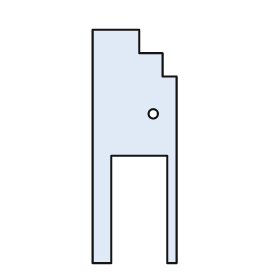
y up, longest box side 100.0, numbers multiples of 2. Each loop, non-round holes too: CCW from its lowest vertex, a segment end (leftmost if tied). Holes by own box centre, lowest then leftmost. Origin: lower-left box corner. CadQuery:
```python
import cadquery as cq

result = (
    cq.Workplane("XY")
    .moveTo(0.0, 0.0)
    .lineTo(8.0, 0.0)
    .lineTo(8.0, 46.0)
    .lineTo(32.0, 46.0)
    .lineTo(32.0, 0.0)
    .lineTo(36.0, 0.0)
    .lineTo(36.0, 80.0)
    .lineTo(30.0, 80.0)
    .lineTo(30.0, 90.0)
    .lineTo(20.0, 90.0)
    .lineTo(20.0, 100.0)
    .lineTo(0.0, 100.0)
    .close()
    .moveTo(26.0, 64.0)
    .circle(2.0)
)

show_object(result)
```